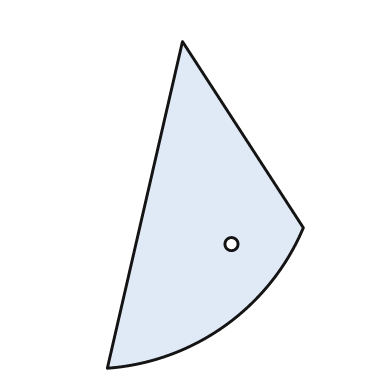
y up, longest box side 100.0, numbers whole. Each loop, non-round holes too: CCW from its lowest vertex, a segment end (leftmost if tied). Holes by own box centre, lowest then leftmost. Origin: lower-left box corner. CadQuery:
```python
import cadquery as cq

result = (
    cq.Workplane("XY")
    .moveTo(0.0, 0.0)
    .threePointArc((36.0, 13.0), (60.0, 43.0))
    .lineTo(23.0, 100.0)
    .close()
    .moveTo(38.0, 38.0)
    .circle(2.0)
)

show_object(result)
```